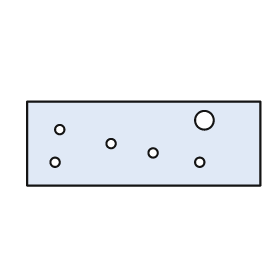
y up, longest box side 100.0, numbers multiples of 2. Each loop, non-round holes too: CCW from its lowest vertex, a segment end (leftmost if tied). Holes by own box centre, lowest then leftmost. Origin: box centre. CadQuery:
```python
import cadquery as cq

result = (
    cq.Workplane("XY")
    .moveTo(-50.0, -18.0)
    .lineTo(50.0, -18.0)
    .lineTo(50.0, 18.0)
    .lineTo(-50.0, 18.0)
    .close()
    .moveTo(-38.0, -8.0)
    .circle(2.0)
    .moveTo(24.0, -8.0)
    .circle(2.0)
    .moveTo(4.0, -4.0)
    .circle(2.0)
    .moveTo(-14.0, 0.0)
    .circle(2.0)
    .moveTo(-36.0, 6.0)
    .circle(2.0)
    .moveTo(26.0, 10.0)
    .circle(4.0)
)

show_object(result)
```